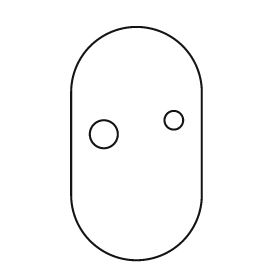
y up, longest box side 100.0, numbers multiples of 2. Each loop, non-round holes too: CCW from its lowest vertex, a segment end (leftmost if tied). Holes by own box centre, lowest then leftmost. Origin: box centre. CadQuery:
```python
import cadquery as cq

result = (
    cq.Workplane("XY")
    .moveTo(-28.0, -22.0)
    .threePointArc((0.0, -50.0), (28.0, -22.0))
    .lineTo(28.0, 22.0)
    .threePointArc((0.0, 50.0), (-28.0, 22.0))
    .close()
    .moveTo(-14.0, 4.0)
    .circle(6.0)
    .moveTo(16.0, 10.0)
    .circle(4.0)
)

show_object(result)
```